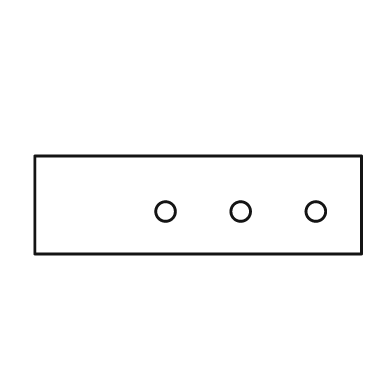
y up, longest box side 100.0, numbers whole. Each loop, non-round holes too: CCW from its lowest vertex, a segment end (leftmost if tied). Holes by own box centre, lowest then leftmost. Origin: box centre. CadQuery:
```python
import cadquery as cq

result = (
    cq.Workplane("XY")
    .moveTo(-50.0, -15.0)
    .lineTo(50.0, -15.0)
    .lineTo(50.0, 15.0)
    .lineTo(-50.0, 15.0)
    .close()
    .moveTo(-10.0, -2.0)
    .circle(3.0)
    .moveTo(13.0, -2.0)
    .circle(3.0)
    .moveTo(36.0, -2.0)
    .circle(3.0)
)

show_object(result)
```